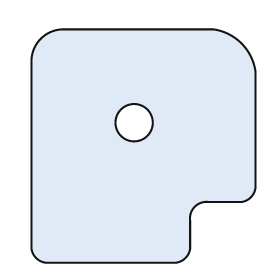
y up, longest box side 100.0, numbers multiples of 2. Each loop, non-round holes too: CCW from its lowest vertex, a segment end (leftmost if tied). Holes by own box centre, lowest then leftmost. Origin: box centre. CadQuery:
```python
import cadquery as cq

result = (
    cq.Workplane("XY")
    .moveTo(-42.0, -50.0)
    .lineTo(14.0, -50.0)
    .threePointArc((18.0, -48.0), (20.0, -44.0))
    .lineTo(20.0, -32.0)
    .threePointArc((22.0, -26.0), (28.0, -24.0))
    .lineTo(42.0, -24.0)
    .threePointArc((46.0, -22.0), (48.0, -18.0))
    .lineTo(48.0, 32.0)
    .threePointArc((42.0, 44.0), (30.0, 50.0))
    .lineTo(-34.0, 50.0)
    .threePointArc((-44.0, 46.0), (-48.0, 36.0))
    .lineTo(-48.0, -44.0)
    .threePointArc((-46.0, -48.0), (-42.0, -50.0))
    .close()
    .moveTo(-4.0, 10.0)
    .circle(8.0)
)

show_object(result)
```